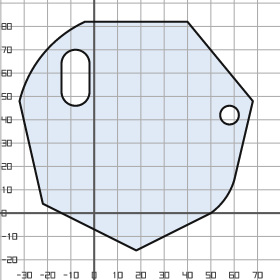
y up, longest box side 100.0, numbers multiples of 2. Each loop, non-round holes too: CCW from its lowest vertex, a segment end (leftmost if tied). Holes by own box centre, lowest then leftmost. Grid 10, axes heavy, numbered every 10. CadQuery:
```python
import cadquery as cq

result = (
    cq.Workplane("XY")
    .moveTo(18.0, -16.0)
    .lineTo(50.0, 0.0)
    .threePointArc((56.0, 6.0), (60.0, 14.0))
    .lineTo(68.0, 48.0)
    .lineTo(40.0, 82.0)
    .lineTo(-4.0, 82.0)
    .threePointArc((-22.0, 68.0), (-32.0, 48.0))
    .lineTo(-22.0, 4.0)
    .close()
    .moveTo(58.0, 42.0)
    .circle(4.0)
    .moveTo(-14.0, 52.0)
    .threePointArc((-8.0, 46.0), (-2.0, 52.0))
    .lineTo(-2.0, 64.0)
    .threePointArc((-8.0, 70.0), (-14.0, 64.0))
    .close()
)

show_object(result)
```